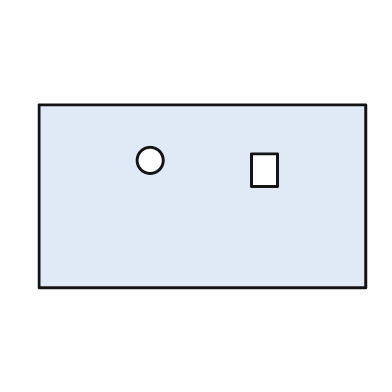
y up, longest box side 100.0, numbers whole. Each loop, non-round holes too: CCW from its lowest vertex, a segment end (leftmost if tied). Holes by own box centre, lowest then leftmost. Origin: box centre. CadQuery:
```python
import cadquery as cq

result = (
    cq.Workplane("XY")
    .moveTo(-50.0, -28.0)
    .lineTo(50.0, -28.0)
    .lineTo(50.0, 28.0)
    .lineTo(-50.0, 28.0)
    .close()
    .moveTo(15.0, 3.0)
    .lineTo(23.0, 3.0)
    .lineTo(23.0, 13.0)
    .lineTo(15.0, 13.0)
    .close()
    .moveTo(-16.0, 11.0)
    .circle(4.0)
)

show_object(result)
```